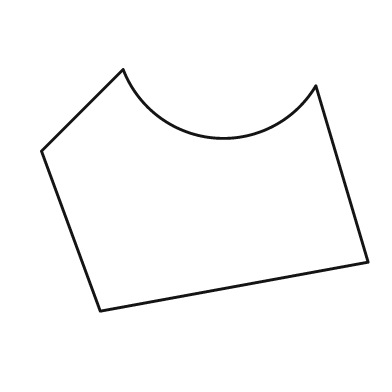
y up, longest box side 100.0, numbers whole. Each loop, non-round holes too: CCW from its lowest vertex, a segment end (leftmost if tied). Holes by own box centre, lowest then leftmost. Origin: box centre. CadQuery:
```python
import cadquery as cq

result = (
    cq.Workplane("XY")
    .moveTo(-32.0, -37.0)
    .lineTo(50.0, -22.0)
    .lineTo(34.0, 32.0)
    .threePointArc((3.0, 16.0), (-25.0, 37.0))
    .lineTo(-50.0, 12.0)
    .close()
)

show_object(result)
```